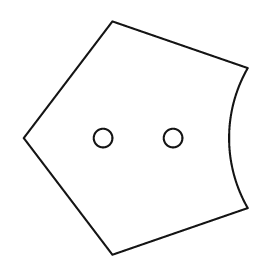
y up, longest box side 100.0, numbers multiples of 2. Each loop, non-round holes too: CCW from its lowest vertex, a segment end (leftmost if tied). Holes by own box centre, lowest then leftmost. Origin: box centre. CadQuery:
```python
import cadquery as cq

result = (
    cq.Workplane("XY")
    .moveTo(-10.0, -50.0)
    .lineTo(48.0, -30.0)
    .threePointArc((40.0, 0.0), (48.0, 30.0))
    .lineTo(-10.0, 50.0)
    .lineTo(-48.0, 0.0)
    .close()
    .moveTo(-14.0, 0.0)
    .circle(4.0)
    .moveTo(16.0, 0.0)
    .circle(4.0)
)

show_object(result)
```